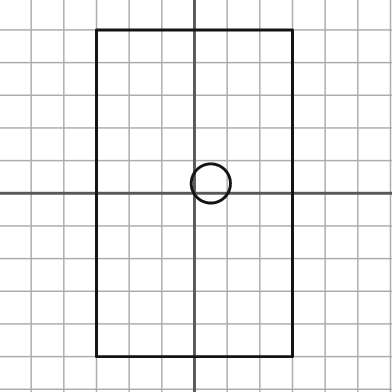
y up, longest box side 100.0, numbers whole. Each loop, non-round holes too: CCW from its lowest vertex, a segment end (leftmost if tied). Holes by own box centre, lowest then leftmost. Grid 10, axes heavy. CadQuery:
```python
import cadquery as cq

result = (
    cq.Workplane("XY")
    .moveTo(-30.0, -50.0)
    .lineTo(30.0, -50.0)
    .lineTo(30.0, 50.0)
    .lineTo(-30.0, 50.0)
    .close()
    .moveTo(5.0, 3.0)
    .circle(6.0)
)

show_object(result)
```